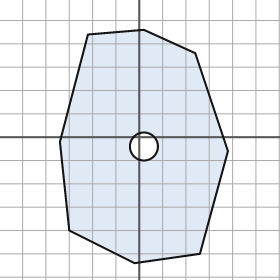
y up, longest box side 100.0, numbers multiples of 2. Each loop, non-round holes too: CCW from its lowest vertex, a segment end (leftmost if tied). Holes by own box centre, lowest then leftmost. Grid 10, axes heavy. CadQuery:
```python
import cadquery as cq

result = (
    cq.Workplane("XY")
    .moveTo(-2.0, -54.0)
    .lineTo(26.0, -50.0)
    .lineTo(38.0, -6.0)
    .lineTo(24.0, 36.0)
    .lineTo(2.0, 46.0)
    .lineTo(-22.0, 44.0)
    .lineTo(-34.0, -2.0)
    .lineTo(-30.0, -40.0)
    .close()
    .moveTo(2.0, -4.0)
    .circle(6.0)
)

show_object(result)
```